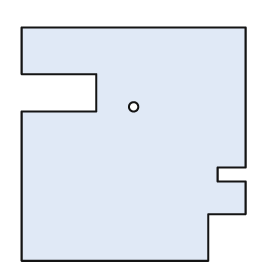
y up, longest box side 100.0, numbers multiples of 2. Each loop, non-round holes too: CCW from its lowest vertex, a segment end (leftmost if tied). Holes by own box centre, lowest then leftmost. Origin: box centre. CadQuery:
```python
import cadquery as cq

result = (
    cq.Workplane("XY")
    .moveTo(-48.0, -50.0)
    .lineTo(32.0, -50.0)
    .lineTo(32.0, -30.0)
    .lineTo(48.0, -30.0)
    .lineTo(48.0, -16.0)
    .lineTo(36.0, -16.0)
    .lineTo(36.0, -10.0)
    .lineTo(48.0, -10.0)
    .lineTo(48.0, 50.0)
    .lineTo(-48.0, 50.0)
    .lineTo(-48.0, 30.0)
    .lineTo(-16.0, 30.0)
    .lineTo(-16.0, 14.0)
    .lineTo(-48.0, 14.0)
    .close()
    .moveTo(0.0, 16.0)
    .circle(2.0)
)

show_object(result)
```